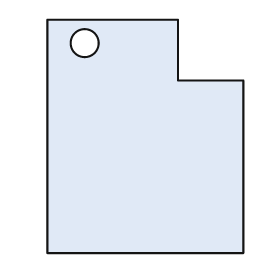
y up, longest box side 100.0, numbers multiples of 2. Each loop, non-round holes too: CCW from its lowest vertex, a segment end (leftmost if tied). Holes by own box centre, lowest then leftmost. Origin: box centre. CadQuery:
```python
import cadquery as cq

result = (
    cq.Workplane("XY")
    .moveTo(-42.0, -50.0)
    .lineTo(42.0, -50.0)
    .lineTo(42.0, 24.0)
    .lineTo(14.0, 24.0)
    .lineTo(14.0, 50.0)
    .lineTo(-42.0, 50.0)
    .close()
    .moveTo(-26.0, 40.0)
    .circle(6.0)
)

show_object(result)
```